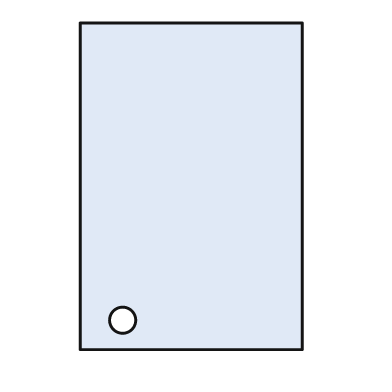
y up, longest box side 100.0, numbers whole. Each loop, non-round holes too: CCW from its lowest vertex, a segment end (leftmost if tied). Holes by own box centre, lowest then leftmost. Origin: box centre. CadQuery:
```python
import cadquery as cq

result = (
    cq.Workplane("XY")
    .moveTo(-34.0, -50.0)
    .lineTo(34.0, -50.0)
    .lineTo(34.0, 50.0)
    .lineTo(-34.0, 50.0)
    .close()
    .moveTo(-21.0, -41.0)
    .circle(4.0)
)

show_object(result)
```